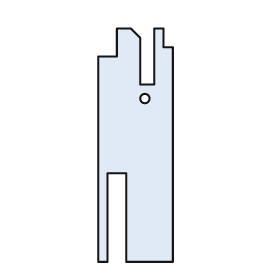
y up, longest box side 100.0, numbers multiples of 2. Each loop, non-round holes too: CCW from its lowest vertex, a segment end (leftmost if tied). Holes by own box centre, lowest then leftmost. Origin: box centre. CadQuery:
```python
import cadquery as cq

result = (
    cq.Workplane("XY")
    .moveTo(-16.0, -50.0)
    .lineTo(-12.0, -50.0)
    .lineTo(-12.0, -12.0)
    .lineTo(-4.0, -12.0)
    .lineTo(-4.0, -50.0)
    .lineTo(16.0, -50.0)
    .lineTo(16.0, 42.0)
    .lineTo(12.0, 42.0)
    .lineTo(12.0, 50.0)
    .lineTo(8.0, 50.0)
    .lineTo(8.0, 26.0)
    .lineTo(2.0, 26.0)
    .lineTo(2.0, 46.0)
    .lineTo(-2.0, 50.0)
    .lineTo(-8.0, 50.0)
    .lineTo(-8.0, 38.0)
    .lineTo(-16.0, 38.0)
    .close()
    .moveTo(4.0, 20.0)
    .circle(2.0)
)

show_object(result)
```